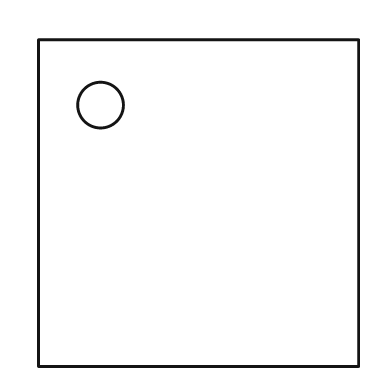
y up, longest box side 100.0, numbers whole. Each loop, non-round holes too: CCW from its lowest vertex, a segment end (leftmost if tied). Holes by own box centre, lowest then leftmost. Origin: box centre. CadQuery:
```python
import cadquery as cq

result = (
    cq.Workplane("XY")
    .moveTo(-49.0, -50.0)
    .lineTo(49.0, -50.0)
    .lineTo(49.0, 50.0)
    .lineTo(-49.0, 50.0)
    .close()
    .moveTo(-30.0, 30.0)
    .circle(7.0)
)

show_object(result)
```